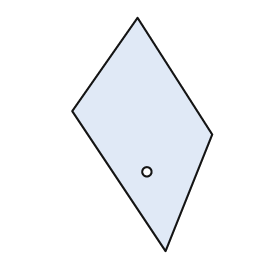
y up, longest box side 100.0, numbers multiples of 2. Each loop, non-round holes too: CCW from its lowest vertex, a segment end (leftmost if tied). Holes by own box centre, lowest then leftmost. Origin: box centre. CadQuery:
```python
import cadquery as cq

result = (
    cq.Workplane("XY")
    .moveTo(10.0, -50.0)
    .lineTo(30.0, 0.0)
    .lineTo(-2.0, 50.0)
    .lineTo(-30.0, 10.0)
    .close()
    .moveTo(2.0, -16.0)
    .circle(2.0)
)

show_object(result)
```